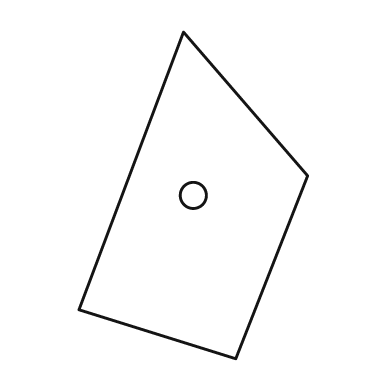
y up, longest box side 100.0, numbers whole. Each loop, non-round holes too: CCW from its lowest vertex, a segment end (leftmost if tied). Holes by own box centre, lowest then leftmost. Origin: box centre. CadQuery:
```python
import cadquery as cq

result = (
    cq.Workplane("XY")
    .moveTo(13.0, -50.0)
    .lineTo(35.0, 6.0)
    .lineTo(-3.0, 50.0)
    .lineTo(-35.0, -35.0)
    .close()
    .moveTo(0.0, 0.0)
    .circle(4.0)
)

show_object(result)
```